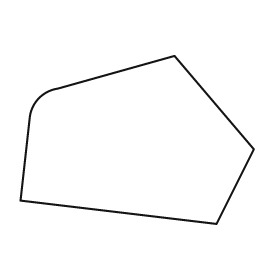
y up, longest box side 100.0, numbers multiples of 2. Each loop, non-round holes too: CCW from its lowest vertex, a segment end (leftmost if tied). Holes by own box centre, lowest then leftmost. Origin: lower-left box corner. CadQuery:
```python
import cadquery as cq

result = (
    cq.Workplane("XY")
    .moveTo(84.0, 0.0)
    .lineTo(100.0, 32.0)
    .lineTo(66.0, 72.0)
    .lineTo(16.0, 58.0)
    .threePointArc((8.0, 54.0), (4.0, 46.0))
    .lineTo(0.0, 10.0)
    .close()
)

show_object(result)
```